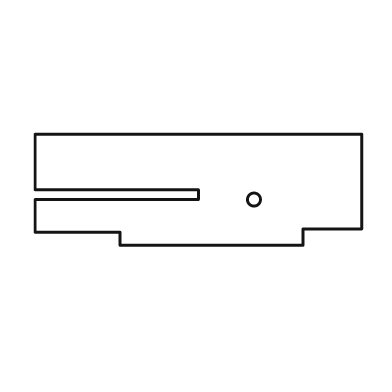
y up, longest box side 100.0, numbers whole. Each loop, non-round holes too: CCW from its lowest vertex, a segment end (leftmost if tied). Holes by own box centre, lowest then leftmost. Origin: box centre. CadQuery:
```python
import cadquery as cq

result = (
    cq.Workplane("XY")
    .moveTo(-24.0, -17.0)
    .lineTo(32.0, -17.0)
    .lineTo(32.0, -12.0)
    .lineTo(50.0, -12.0)
    .lineTo(50.0, 17.0)
    .lineTo(-50.0, 17.0)
    .lineTo(-50.0, 0.0)
    .lineTo(0.0, 0.0)
    .lineTo(0.0, -3.0)
    .lineTo(-50.0, -3.0)
    .lineTo(-50.0, -13.0)
    .lineTo(-24.0, -13.0)
    .close()
    .moveTo(17.0, -3.0)
    .circle(2.0)
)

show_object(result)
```